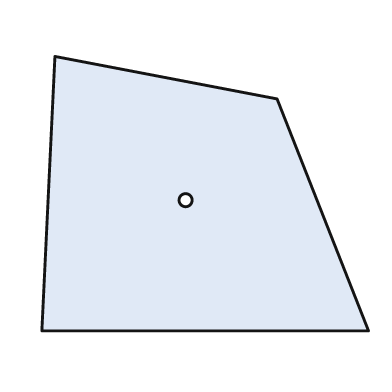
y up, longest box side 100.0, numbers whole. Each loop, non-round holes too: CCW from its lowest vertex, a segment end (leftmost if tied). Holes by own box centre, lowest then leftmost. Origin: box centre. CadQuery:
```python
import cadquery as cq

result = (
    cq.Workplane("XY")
    .moveTo(-50.0, -42.0)
    .lineTo(50.0, -42.0)
    .lineTo(22.0, 29.0)
    .lineTo(-46.0, 42.0)
    .close()
    .moveTo(-6.0, -2.0)
    .circle(2.0)
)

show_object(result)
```